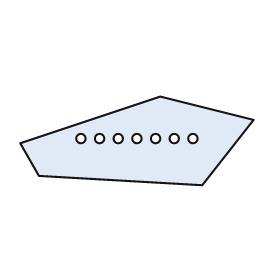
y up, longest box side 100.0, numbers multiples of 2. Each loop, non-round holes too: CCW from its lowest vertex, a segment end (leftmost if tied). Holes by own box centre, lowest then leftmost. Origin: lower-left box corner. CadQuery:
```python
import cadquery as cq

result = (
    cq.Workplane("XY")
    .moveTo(78.0, 0.0)
    .lineTo(100.0, 28.0)
    .lineTo(60.0, 38.0)
    .lineTo(0.0, 18.0)
    .lineTo(8.0, 4.0)
    .close()
    .moveTo(26.0, 20.0)
    .circle(2.0)
    .moveTo(34.0, 20.0)
    .circle(2.0)
    .moveTo(42.0, 20.0)
    .circle(2.0)
    .moveTo(50.0, 20.0)
    .circle(2.0)
    .moveTo(58.0, 20.0)
    .circle(2.0)
    .moveTo(66.0, 20.0)
    .circle(2.0)
    .moveTo(74.0, 20.0)
    .circle(2.0)
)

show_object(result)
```